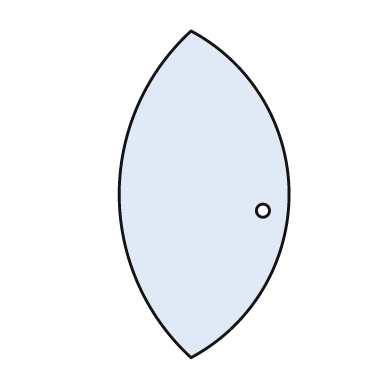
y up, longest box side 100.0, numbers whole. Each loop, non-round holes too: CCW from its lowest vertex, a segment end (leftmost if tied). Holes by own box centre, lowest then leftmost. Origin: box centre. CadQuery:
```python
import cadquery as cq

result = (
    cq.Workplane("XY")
    .moveTo(-4.0, -50.0)
    .threePointArc((26.0, 0.0), (-4.0, 50.0))
    .threePointArc((-26.0, 0.0), (-4.0, -50.0))
    .close()
    .moveTo(18.0, -5.0)
    .circle(2.0)
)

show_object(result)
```